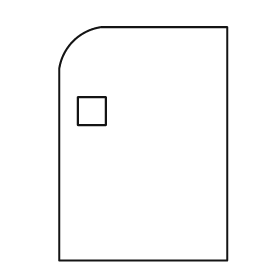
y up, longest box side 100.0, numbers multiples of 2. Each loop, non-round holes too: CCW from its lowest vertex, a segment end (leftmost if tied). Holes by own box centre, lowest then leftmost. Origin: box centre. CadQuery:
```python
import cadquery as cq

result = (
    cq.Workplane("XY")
    .moveTo(-36.0, -50.0)
    .lineTo(36.0, -50.0)
    .lineTo(36.0, 50.0)
    .lineTo(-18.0, 50.0)
    .threePointArc((-30.0, 44.0), (-36.0, 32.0))
    .close()
    .moveTo(-28.0, 8.0)
    .lineTo(-16.0, 8.0)
    .lineTo(-16.0, 20.0)
    .lineTo(-28.0, 20.0)
    .close()
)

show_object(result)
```